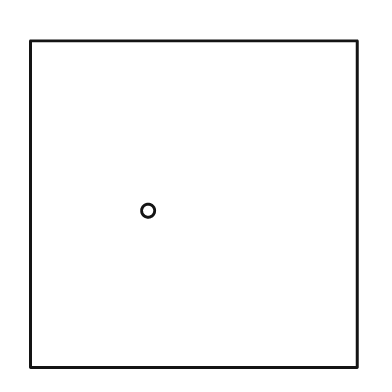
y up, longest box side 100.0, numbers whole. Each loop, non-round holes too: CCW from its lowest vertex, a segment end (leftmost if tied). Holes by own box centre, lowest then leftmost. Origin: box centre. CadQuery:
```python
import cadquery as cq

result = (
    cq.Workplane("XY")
    .moveTo(-50.0, -50.0)
    .lineTo(50.0, -50.0)
    .lineTo(50.0, 50.0)
    .lineTo(-50.0, 50.0)
    .close()
    .moveTo(-14.0, -2.0)
    .circle(2.0)
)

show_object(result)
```